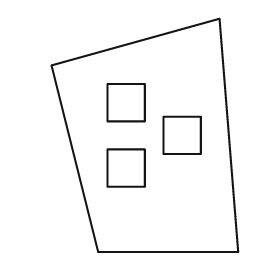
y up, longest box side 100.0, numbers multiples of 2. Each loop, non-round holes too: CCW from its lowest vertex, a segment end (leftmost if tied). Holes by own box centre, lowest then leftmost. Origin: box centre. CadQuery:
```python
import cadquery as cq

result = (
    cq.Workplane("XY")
    .moveTo(-20.0, -50.0)
    .lineTo(40.0, -50.0)
    .lineTo(32.0, 50.0)
    .lineTo(-40.0, 30.0)
    .close()
    .moveTo(-16.0, -22.0)
    .lineTo(0.0, -22.0)
    .lineTo(0.0, -6.0)
    .lineTo(-16.0, -6.0)
    .close()
    .moveTo(8.0, -8.0)
    .lineTo(24.0, -8.0)
    .lineTo(24.0, 8.0)
    .lineTo(8.0, 8.0)
    .close()
    .moveTo(-16.0, 6.0)
    .lineTo(0.0, 6.0)
    .lineTo(0.0, 22.0)
    .lineTo(-16.0, 22.0)
    .close()
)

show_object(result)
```